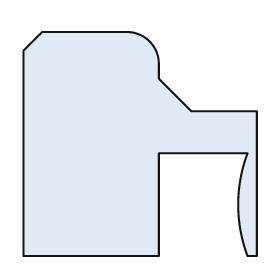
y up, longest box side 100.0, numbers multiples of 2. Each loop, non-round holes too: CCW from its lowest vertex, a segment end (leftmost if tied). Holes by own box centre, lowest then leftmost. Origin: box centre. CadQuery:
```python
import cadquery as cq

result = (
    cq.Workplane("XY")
    .moveTo(-50.0, -48.0)
    .lineTo(8.0, -48.0)
    .lineTo(8.0, -4.0)
    .lineTo(46.0, -4.0)
    .threePointArc((42.0, -26.0), (46.0, -48.0))
    .lineTo(50.0, -48.0)
    .lineTo(50.0, 14.0)
    .lineTo(22.0, 14.0)
    .lineTo(8.0, 28.0)
    .lineTo(8.0, 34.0)
    .threePointArc((4.0, 44.0), (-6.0, 48.0))
    .lineTo(-42.0, 48.0)
    .lineTo(-50.0, 40.0)
    .close()
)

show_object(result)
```